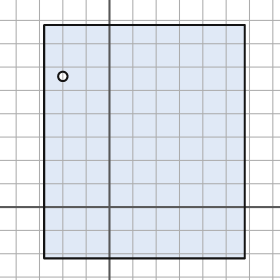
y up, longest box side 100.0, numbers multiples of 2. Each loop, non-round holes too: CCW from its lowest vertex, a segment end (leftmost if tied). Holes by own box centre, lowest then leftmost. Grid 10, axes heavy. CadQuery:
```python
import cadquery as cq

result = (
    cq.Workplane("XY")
    .moveTo(-28.0, -22.0)
    .lineTo(58.0, -22.0)
    .lineTo(58.0, 78.0)
    .lineTo(-28.0, 78.0)
    .close()
    .moveTo(-20.0, 56.0)
    .circle(2.0)
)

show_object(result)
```